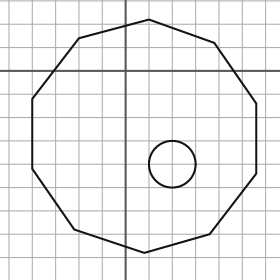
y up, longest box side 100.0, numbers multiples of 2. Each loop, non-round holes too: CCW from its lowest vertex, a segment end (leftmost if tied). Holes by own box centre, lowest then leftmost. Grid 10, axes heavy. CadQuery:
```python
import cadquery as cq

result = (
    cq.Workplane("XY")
    .moveTo(8.0, -78.0)
    .lineTo(36.0, -70.0)
    .lineTo(56.0, -44.0)
    .lineTo(56.0, -14.0)
    .lineTo(38.0, 12.0)
    .lineTo(10.0, 22.0)
    .lineTo(-20.0, 14.0)
    .lineTo(-40.0, -12.0)
    .lineTo(-40.0, -42.0)
    .lineTo(-22.0, -68.0)
    .close()
    .moveTo(20.0, -40.0)
    .circle(10.0)
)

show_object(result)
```